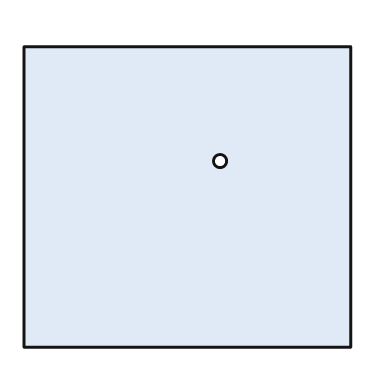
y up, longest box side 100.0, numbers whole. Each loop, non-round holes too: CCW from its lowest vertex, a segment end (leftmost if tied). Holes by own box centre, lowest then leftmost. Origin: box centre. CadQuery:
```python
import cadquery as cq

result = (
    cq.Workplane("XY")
    .moveTo(-50.0, -46.0)
    .lineTo(50.0, -46.0)
    .lineTo(50.0, 46.0)
    .lineTo(-50.0, 46.0)
    .close()
    .moveTo(10.0, 11.0)
    .circle(2.0)
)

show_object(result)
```